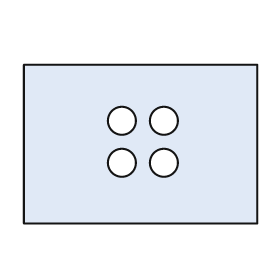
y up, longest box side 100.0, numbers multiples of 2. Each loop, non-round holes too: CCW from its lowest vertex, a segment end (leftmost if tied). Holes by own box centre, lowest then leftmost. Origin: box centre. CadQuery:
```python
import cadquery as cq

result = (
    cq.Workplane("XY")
    .moveTo(-50.0, -34.0)
    .lineTo(50.0, -34.0)
    .lineTo(50.0, 34.0)
    .lineTo(-50.0, 34.0)
    .close()
    .moveTo(-8.0, -8.0)
    .circle(6.0)
    .moveTo(10.0, -8.0)
    .circle(6.0)
    .moveTo(-8.0, 10.0)
    .circle(6.0)
    .moveTo(10.0, 10.0)
    .circle(6.0)
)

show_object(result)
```